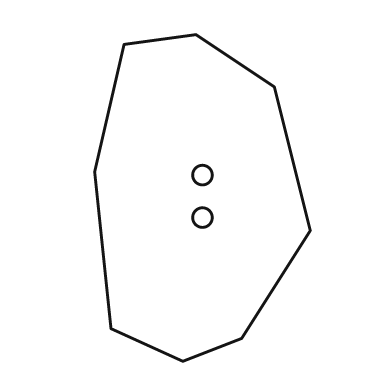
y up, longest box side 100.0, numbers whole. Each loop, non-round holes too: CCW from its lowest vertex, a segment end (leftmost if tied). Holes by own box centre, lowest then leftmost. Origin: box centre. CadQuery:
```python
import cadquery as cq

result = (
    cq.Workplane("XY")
    .moveTo(-6.0, -50.0)
    .lineTo(12.0, -43.0)
    .lineTo(33.0, -10.0)
    .lineTo(22.0, 34.0)
    .lineTo(-2.0, 50.0)
    .lineTo(-24.0, 47.0)
    .lineTo(-33.0, 8.0)
    .lineTo(-28.0, -40.0)
    .close()
    .moveTo(0.0, -6.0)
    .circle(3.0)
    .moveTo(0.0, 7.0)
    .circle(3.0)
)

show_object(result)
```